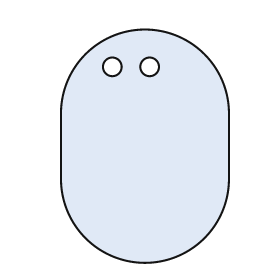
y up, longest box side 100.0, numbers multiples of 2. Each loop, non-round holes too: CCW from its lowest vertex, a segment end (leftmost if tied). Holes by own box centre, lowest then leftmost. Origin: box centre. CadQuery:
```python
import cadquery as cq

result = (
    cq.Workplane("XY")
    .moveTo(-36.0, -14.0)
    .threePointArc((0.0, -50.0), (36.0, -14.0))
    .lineTo(36.0, 14.0)
    .threePointArc((0.0, 50.0), (-36.0, 14.0))
    .close()
    .moveTo(-14.0, 34.0)
    .circle(4.0)
    .moveTo(2.0, 34.0)
    .circle(4.0)
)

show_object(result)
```